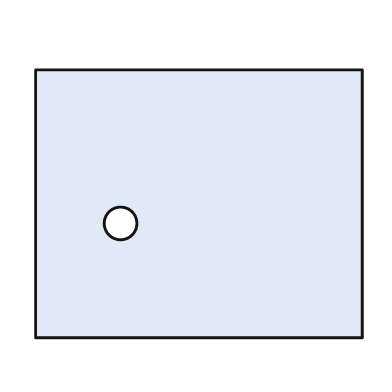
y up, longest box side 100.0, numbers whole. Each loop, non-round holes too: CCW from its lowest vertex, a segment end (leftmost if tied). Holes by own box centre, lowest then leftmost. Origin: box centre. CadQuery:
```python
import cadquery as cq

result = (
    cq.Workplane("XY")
    .moveTo(-50.0, -41.0)
    .lineTo(50.0, -41.0)
    .lineTo(50.0, 41.0)
    .lineTo(-50.0, 41.0)
    .close()
    .moveTo(-24.0, -6.0)
    .circle(5.0)
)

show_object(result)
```